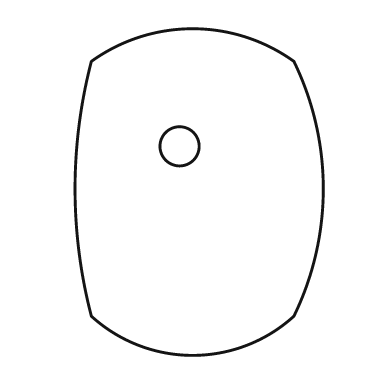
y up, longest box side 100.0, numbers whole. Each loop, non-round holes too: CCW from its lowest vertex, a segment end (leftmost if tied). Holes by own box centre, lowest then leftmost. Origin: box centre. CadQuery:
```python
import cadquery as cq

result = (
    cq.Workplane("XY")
    .moveTo(-33.0, -38.0)
    .threePointArc((-2.0, -50.0), (29.0, -38.0))
    .threePointArc((38.0, 1.0), (29.0, 40.0))
    .threePointArc((-2.0, 50.0), (-33.0, 40.0))
    .threePointArc((-38.0, 1.0), (-33.0, -38.0))
    .close()
    .moveTo(-6.0, 14.0)
    .circle(6.0)
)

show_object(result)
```